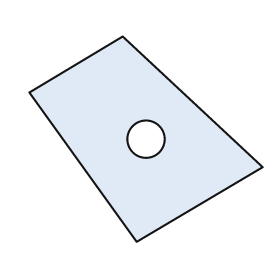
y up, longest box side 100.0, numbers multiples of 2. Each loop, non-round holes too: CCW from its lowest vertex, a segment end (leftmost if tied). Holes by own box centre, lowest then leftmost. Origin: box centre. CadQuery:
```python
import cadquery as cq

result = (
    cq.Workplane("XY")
    .moveTo(-4.0, -44.0)
    .lineTo(50.0, -12.0)
    .lineTo(-10.0, 44.0)
    .lineTo(-50.0, 20.0)
    .close()
    .moveTo(0.0, 0.0)
    .circle(8.0)
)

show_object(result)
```